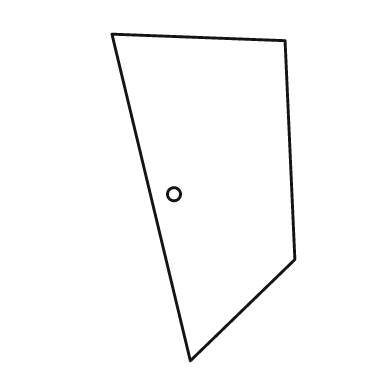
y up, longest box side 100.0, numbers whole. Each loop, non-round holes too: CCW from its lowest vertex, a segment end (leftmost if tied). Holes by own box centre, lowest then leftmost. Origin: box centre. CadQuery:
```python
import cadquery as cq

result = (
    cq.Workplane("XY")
    .moveTo(-4.0, -50.0)
    .lineTo(28.0, -19.0)
    .lineTo(25.0, 48.0)
    .lineTo(-28.0, 50.0)
    .close()
    .moveTo(-9.0, 1.0)
    .circle(2.0)
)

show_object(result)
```